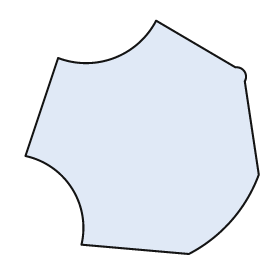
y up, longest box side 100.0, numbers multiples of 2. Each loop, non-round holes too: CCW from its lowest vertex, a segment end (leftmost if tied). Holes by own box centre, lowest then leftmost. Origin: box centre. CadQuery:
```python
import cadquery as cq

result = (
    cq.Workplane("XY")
    .moveTo(20.0, -50.0)
    .threePointArc((38.0, -36.0), (50.0, -16.0))
    .lineTo(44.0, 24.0)
    .threePointArc((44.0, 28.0), (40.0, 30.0))
    .lineTo(6.0, 50.0)
    .threePointArc((-12.0, 34.0), (-36.0, 34.0))
    .lineTo(-50.0, -8.0)
    .threePointArc((-30.0, -22.0), (-26.0, -46.0))
    .close()
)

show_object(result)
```